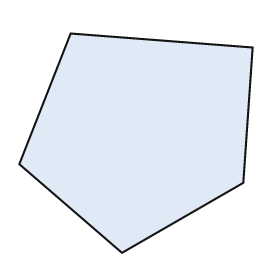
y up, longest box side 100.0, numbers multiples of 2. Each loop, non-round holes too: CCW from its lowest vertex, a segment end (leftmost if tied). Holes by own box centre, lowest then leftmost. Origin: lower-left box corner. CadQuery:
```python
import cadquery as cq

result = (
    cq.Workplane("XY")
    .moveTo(44.0, 0.0)
    .lineTo(96.0, 30.0)
    .lineTo(100.0, 88.0)
    .lineTo(22.0, 94.0)
    .lineTo(0.0, 38.0)
    .close()
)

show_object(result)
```